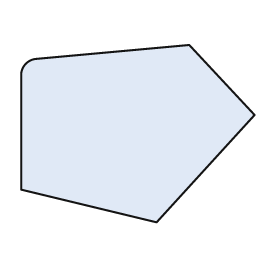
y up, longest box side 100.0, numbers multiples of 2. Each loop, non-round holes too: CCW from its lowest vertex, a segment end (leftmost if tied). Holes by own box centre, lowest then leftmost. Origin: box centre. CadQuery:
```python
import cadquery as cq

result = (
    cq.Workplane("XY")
    .moveTo(8.0, -38.0)
    .lineTo(50.0, 8.0)
    .lineTo(22.0, 38.0)
    .lineTo(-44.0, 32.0)
    .threePointArc((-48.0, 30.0), (-50.0, 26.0))
    .lineTo(-50.0, -24.0)
    .close()
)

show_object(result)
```